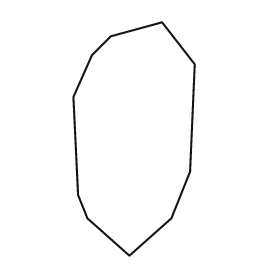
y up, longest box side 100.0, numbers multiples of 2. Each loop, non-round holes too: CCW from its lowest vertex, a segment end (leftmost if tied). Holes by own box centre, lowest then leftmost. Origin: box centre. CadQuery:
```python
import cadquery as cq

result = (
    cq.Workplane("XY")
    .moveTo(-2.0, -50.0)
    .lineTo(16.0, -34.0)
    .lineTo(24.0, -14.0)
    .lineTo(26.0, 32.0)
    .lineTo(12.0, 50.0)
    .lineTo(-10.0, 44.0)
    .lineTo(-18.0, 36.0)
    .lineTo(-26.0, 18.0)
    .lineTo(-24.0, -24.0)
    .lineTo(-20.0, -34.0)
    .close()
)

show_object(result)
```